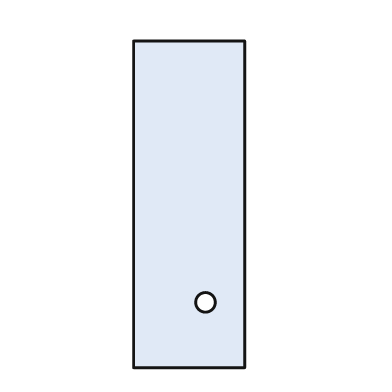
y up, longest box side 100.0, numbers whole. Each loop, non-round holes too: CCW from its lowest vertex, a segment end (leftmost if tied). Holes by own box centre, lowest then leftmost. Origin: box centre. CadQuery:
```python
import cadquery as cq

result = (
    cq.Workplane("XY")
    .moveTo(-17.0, -50.0)
    .lineTo(17.0, -50.0)
    .lineTo(17.0, 50.0)
    .lineTo(-17.0, 50.0)
    .close()
    .moveTo(5.0, -30.0)
    .circle(3.0)
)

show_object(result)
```